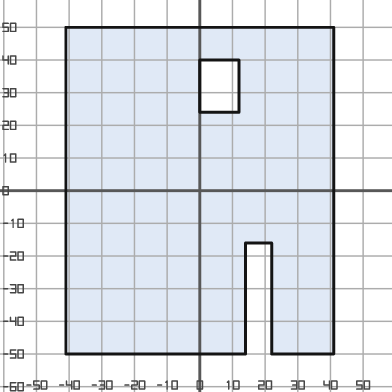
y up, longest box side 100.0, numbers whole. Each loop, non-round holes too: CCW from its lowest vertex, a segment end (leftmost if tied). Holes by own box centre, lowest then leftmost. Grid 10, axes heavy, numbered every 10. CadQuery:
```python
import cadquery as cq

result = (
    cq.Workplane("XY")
    .moveTo(-41.0, -50.0)
    .lineTo(14.0, -50.0)
    .lineTo(14.0, -16.0)
    .lineTo(22.0, -16.0)
    .lineTo(22.0, -50.0)
    .lineTo(41.0, -50.0)
    .lineTo(41.0, 50.0)
    .lineTo(-41.0, 50.0)
    .close()
    .moveTo(0.0, 24.0)
    .lineTo(12.0, 24.0)
    .lineTo(12.0, 40.0)
    .lineTo(0.0, 40.0)
    .close()
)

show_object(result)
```